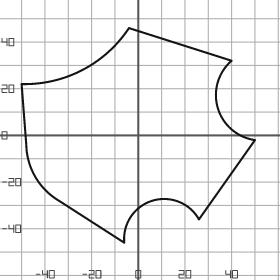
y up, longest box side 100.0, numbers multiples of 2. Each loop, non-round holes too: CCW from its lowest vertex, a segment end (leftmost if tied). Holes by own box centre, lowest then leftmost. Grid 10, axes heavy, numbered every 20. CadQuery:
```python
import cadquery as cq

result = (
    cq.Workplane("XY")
    .moveTo(-6.0, -46.0)
    .threePointArc((6.0, -28.0), (26.0, -36.0))
    .lineTo(50.0, -2.0)
    .threePointArc((34.0, 12.0), (40.0, 32.0))
    .lineTo(-4.0, 46.0)
    .threePointArc((-24.0, 28.0), (-50.0, 22.0))
    .lineTo(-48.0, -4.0)
    .threePointArc((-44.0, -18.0), (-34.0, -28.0))
    .close()
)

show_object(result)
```